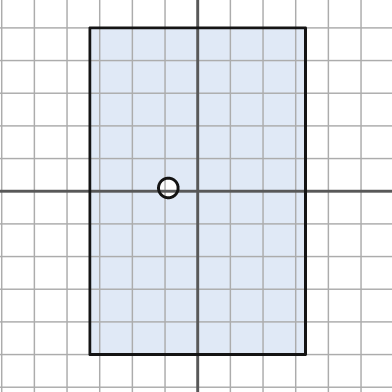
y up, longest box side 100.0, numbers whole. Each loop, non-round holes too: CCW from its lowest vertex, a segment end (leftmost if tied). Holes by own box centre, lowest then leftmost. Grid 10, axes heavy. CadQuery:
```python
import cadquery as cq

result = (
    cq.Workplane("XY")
    .moveTo(-33.0, -50.0)
    .lineTo(33.0, -50.0)
    .lineTo(33.0, 50.0)
    .lineTo(-33.0, 50.0)
    .close()
    .moveTo(-9.0, 1.0)
    .circle(3.0)
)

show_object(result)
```